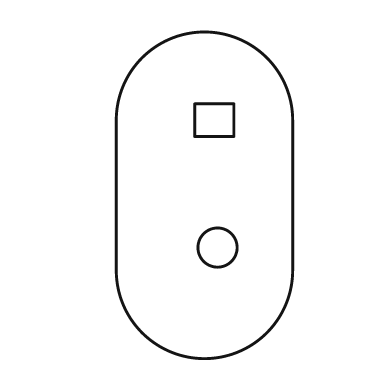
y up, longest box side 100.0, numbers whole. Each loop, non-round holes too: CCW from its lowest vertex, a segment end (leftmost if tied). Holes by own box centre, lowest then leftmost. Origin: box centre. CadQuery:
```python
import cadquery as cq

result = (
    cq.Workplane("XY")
    .moveTo(-27.0, -23.0)
    .threePointArc((0.0, -50.0), (27.0, -23.0))
    .lineTo(27.0, 23.0)
    .threePointArc((0.0, 50.0), (-27.0, 23.0))
    .close()
    .moveTo(4.0, -16.0)
    .circle(6.0)
    .moveTo(-3.0, 18.0)
    .lineTo(9.0, 18.0)
    .lineTo(9.0, 28.0)
    .lineTo(-3.0, 28.0)
    .close()
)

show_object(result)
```